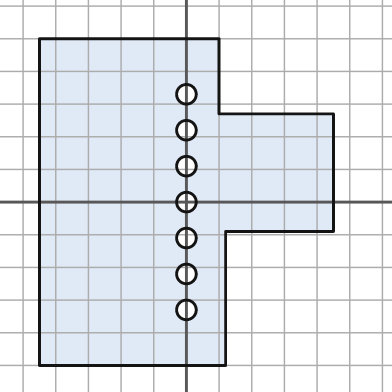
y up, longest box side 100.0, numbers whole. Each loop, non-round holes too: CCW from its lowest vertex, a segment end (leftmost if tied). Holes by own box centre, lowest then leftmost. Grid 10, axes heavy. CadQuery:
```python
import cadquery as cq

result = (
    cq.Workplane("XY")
    .moveTo(-45.0, -50.0)
    .lineTo(12.0, -50.0)
    .lineTo(12.0, -9.0)
    .lineTo(45.0, -9.0)
    .lineTo(45.0, 27.0)
    .lineTo(10.0, 27.0)
    .lineTo(10.0, 50.0)
    .lineTo(-45.0, 50.0)
    .close()
    .moveTo(0.0, -33.0)
    .circle(3.0)
    .moveTo(0.0, -22.0)
    .circle(3.0)
    .moveTo(0.0, -11.0)
    .circle(3.0)
    .moveTo(0.0, 0.0)
    .circle(3.0)
    .moveTo(0.0, 11.0)
    .circle(3.0)
    .moveTo(0.0, 22.0)
    .circle(3.0)
    .moveTo(0.0, 33.0)
    .circle(3.0)
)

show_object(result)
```